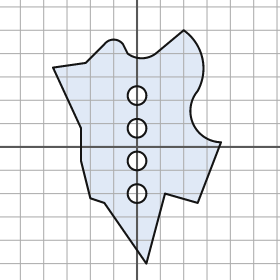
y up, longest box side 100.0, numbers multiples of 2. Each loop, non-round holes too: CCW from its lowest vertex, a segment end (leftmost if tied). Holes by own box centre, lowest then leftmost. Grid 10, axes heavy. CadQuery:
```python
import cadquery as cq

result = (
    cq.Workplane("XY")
    .moveTo(4.0, -50.0)
    .lineTo(12.0, -20.0)
    .lineTo(26.0, -24.0)
    .lineTo(36.0, 2.0)
    .threePointArc((24.0, 10.0), (26.0, 24.0))
    .threePointArc((28.0, 38.0), (20.0, 50.0))
    .lineTo(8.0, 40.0)
    .threePointArc((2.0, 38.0), (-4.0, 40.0))
    .lineTo(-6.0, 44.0)
    .threePointArc((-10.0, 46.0), (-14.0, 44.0))
    .lineTo(-22.0, 36.0)
    .lineTo(-36.0, 34.0)
    .lineTo(-24.0, 8.0)
    .lineTo(-24.0, -6.0)
    .lineTo(-20.0, -22.0)
    .lineTo(-14.0, -24.0)
    .close()
    .moveTo(0.0, -20.0)
    .circle(4.0)
    .moveTo(0.0, -6.0)
    .circle(4.0)
    .moveTo(0.0, 8.0)
    .circle(4.0)
    .moveTo(0.0, 22.0)
    .circle(4.0)
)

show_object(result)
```